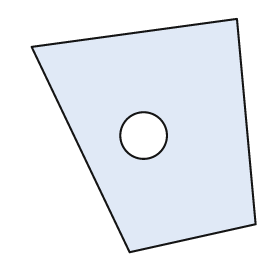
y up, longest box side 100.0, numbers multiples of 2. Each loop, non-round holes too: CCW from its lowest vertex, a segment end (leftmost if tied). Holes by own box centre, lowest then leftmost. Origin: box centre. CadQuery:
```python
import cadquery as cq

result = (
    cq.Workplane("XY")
    .moveTo(-6.0, -50.0)
    .lineTo(48.0, -38.0)
    .lineTo(40.0, 50.0)
    .lineTo(-48.0, 38.0)
    .close()
    .moveTo(0.0, 0.0)
    .circle(10.0)
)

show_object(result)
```